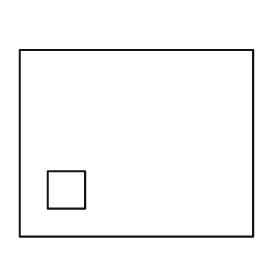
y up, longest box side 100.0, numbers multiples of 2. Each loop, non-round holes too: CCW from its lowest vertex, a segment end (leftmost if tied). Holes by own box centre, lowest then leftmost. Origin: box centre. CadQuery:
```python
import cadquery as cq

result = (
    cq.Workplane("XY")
    .moveTo(-50.0, -40.0)
    .lineTo(50.0, -40.0)
    .lineTo(50.0, 40.0)
    .lineTo(-50.0, 40.0)
    .close()
    .moveTo(-38.0, -28.0)
    .lineTo(-22.0, -28.0)
    .lineTo(-22.0, -12.0)
    .lineTo(-38.0, -12.0)
    .close()
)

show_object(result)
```